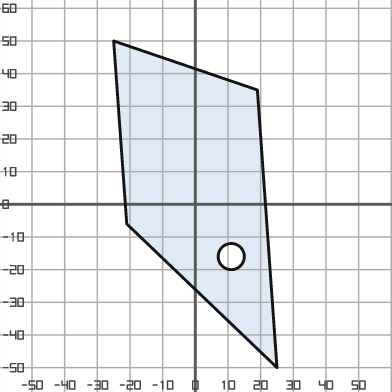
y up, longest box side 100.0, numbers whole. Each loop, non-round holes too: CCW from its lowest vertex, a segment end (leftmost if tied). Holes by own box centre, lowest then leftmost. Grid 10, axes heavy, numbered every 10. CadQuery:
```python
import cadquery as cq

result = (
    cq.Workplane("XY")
    .moveTo(25.0, -50.0)
    .lineTo(19.0, 35.0)
    .lineTo(-25.0, 50.0)
    .lineTo(-21.0, -6.0)
    .close()
    .moveTo(11.0, -16.0)
    .circle(4.0)
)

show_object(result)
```